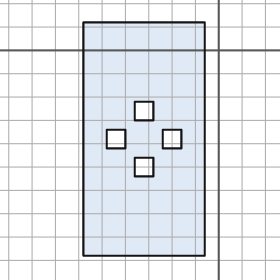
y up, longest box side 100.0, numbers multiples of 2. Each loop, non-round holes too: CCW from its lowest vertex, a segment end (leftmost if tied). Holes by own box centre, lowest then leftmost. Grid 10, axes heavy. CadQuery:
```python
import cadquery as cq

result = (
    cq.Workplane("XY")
    .moveTo(-58.0, -88.0)
    .lineTo(-6.0, -88.0)
    .lineTo(-6.0, 12.0)
    .lineTo(-58.0, 12.0)
    .close()
    .moveTo(-36.0, -54.0)
    .lineTo(-28.0, -54.0)
    .lineTo(-28.0, -46.0)
    .lineTo(-36.0, -46.0)
    .close()
    .moveTo(-48.0, -42.0)
    .lineTo(-40.0, -42.0)
    .lineTo(-40.0, -34.0)
    .lineTo(-48.0, -34.0)
    .close()
    .moveTo(-24.0, -42.0)
    .lineTo(-16.0, -42.0)
    .lineTo(-16.0, -34.0)
    .lineTo(-24.0, -34.0)
    .close()
    .moveTo(-36.0, -30.0)
    .lineTo(-28.0, -30.0)
    .lineTo(-28.0, -22.0)
    .lineTo(-36.0, -22.0)
    .close()
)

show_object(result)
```